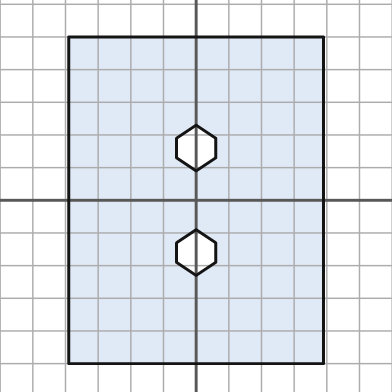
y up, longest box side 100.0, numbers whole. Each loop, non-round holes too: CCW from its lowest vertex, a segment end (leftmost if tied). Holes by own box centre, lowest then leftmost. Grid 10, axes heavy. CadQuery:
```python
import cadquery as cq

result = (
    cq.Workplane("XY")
    .moveTo(-39.0, -50.0)
    .lineTo(39.0, -50.0)
    .lineTo(39.0, 50.0)
    .lineTo(-39.0, 50.0)
    .close()
    .moveTo(0.0, -23.0)
    .lineTo(6.0, -19.0)
    .lineTo(6.0, -13.0)
    .lineTo(0.0, -9.0)
    .lineTo(-6.0, -13.0)
    .lineTo(-6.0, -19.0)
    .close()
    .moveTo(0.0, 9.0)
    .lineTo(6.0, 13.0)
    .lineTo(6.0, 19.0)
    .lineTo(0.0, 23.0)
    .lineTo(-6.0, 19.0)
    .lineTo(-6.0, 13.0)
    .close()
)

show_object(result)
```